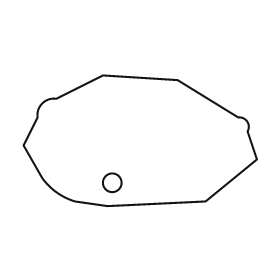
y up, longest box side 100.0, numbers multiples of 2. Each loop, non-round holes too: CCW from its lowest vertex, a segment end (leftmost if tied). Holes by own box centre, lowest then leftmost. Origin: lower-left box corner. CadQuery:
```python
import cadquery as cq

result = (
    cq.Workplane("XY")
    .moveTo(36.0, 0.0)
    .lineTo(78.0, 2.0)
    .lineTo(100.0, 20.0)
    .lineTo(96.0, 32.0)
    .threePointArc((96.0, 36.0), (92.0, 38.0))
    .lineTo(66.0, 54.0)
    .lineTo(34.0, 56.0)
    .lineTo(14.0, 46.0)
    .threePointArc((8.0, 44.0), (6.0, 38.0))
    .lineTo(0.0, 26.0)
    .lineTo(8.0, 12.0)
    .threePointArc((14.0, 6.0), (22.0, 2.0))
    .close()
    .moveTo(38.0, 10.0)
    .circle(4.0)
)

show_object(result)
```